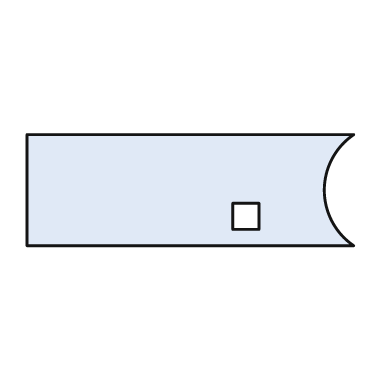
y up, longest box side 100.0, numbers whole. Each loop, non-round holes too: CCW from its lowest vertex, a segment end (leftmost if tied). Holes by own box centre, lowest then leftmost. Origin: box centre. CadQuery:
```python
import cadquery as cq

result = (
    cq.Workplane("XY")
    .moveTo(-50.0, -17.0)
    .lineTo(50.0, -17.0)
    .threePointArc((41.0, 0.0), (50.0, 17.0))
    .lineTo(-50.0, 17.0)
    .close()
    .moveTo(13.0, -12.0)
    .lineTo(21.0, -12.0)
    .lineTo(21.0, -4.0)
    .lineTo(13.0, -4.0)
    .close()
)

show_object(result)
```